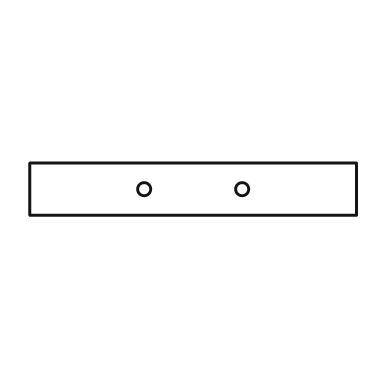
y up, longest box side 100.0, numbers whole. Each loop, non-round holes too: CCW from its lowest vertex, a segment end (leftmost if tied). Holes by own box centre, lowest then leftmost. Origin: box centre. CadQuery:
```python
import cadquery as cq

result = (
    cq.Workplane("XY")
    .moveTo(-50.0, -8.0)
    .lineTo(50.0, -8.0)
    .lineTo(50.0, 8.0)
    .lineTo(-50.0, 8.0)
    .close()
    .moveTo(-15.0, 0.0)
    .circle(2.0)
    .moveTo(15.0, 0.0)
    .circle(2.0)
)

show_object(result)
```